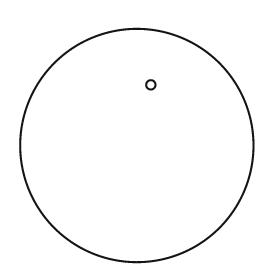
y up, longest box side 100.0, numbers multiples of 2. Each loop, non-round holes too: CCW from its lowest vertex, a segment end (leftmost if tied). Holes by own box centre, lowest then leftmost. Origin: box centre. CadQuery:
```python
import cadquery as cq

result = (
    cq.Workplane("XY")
    .moveTo(0.0, 0.0)
    .circle(50.0)
    .moveTo(6.0, 26.0)
    .circle(2.0)
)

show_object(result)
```